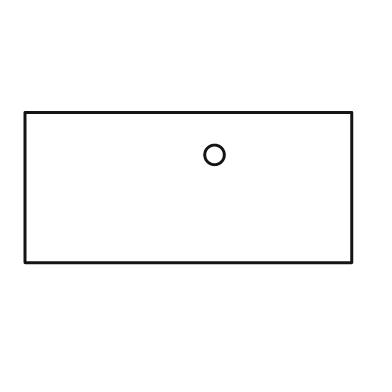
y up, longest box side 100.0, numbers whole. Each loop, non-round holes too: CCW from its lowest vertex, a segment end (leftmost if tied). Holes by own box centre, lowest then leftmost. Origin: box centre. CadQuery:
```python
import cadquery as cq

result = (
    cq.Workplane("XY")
    .moveTo(-50.0, -23.0)
    .lineTo(50.0, -23.0)
    .lineTo(50.0, 23.0)
    .lineTo(-50.0, 23.0)
    .close()
    .moveTo(8.0, 10.0)
    .circle(3.0)
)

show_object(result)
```